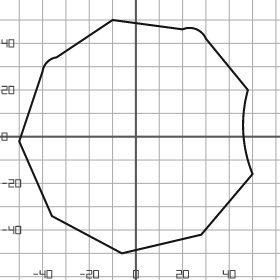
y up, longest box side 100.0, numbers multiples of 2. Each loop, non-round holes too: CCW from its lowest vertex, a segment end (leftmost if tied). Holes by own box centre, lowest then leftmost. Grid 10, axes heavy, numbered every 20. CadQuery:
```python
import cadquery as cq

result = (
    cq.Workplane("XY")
    .moveTo(-6.0, -50.0)
    .lineTo(28.0, -42.0)
    .lineTo(50.0, -16.0)
    .threePointArc((46.0, 2.0), (48.0, 20.0))
    .lineTo(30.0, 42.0)
    .threePointArc((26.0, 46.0), (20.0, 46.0))
    .lineTo(-10.0, 50.0)
    .lineTo(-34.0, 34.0)
    .threePointArc((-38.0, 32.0), (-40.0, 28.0))
    .lineTo(-50.0, -2.0)
    .lineTo(-36.0, -34.0)
    .close()
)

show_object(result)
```